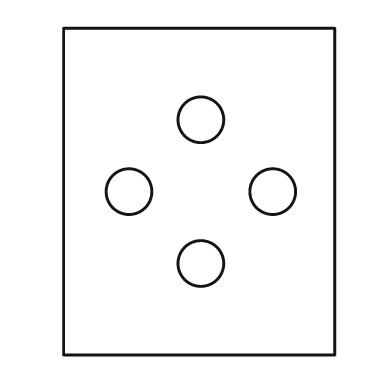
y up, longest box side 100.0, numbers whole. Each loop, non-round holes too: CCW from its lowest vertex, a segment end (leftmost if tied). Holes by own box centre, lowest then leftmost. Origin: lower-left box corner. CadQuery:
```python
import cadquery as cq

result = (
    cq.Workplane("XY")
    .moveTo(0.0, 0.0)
    .lineTo(83.0, 0.0)
    .lineTo(83.0, 100.0)
    .lineTo(0.0, 100.0)
    .close()
    .moveTo(42.0, 28.0)
    .circle(7.0)
    .moveTo(20.0, 50.0)
    .circle(7.0)
    .moveTo(64.0, 50.0)
    .circle(7.0)
    .moveTo(42.0, 72.0)
    .circle(7.0)
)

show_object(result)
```